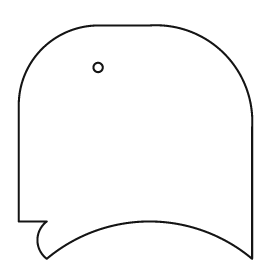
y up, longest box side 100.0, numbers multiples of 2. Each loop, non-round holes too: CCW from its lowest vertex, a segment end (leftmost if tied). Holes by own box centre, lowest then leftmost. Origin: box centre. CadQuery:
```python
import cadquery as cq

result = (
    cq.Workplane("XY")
    .moveTo(-38.0, -50.0)
    .threePointArc((6.0, -34.0), (50.0, -50.0))
    .lineTo(50.0, 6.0)
    .threePointArc((38.0, 38.0), (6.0, 50.0))
    .lineTo(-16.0, 50.0)
    .threePointArc((-40.0, 40.0), (-50.0, 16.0))
    .lineTo(-50.0, -34.0)
    .lineTo(-38.0, -34.0)
    .threePointArc((-42.0, -42.0), (-38.0, -50.0))
    .close()
    .moveTo(-16.0, 32.0)
    .circle(2.0)
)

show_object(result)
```